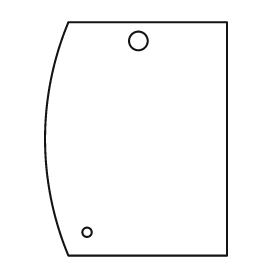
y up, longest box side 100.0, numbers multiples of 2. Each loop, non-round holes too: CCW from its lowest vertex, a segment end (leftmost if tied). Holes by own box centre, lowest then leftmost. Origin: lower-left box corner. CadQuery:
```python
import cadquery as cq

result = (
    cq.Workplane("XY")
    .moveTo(10.0, 0.0)
    .lineTo(78.0, 0.0)
    .lineTo(78.0, 100.0)
    .lineTo(10.0, 100.0)
    .threePointArc((0.0, 50.0), (10.0, 0.0))
    .close()
    .moveTo(18.0, 10.0)
    .circle(2.0)
    .moveTo(40.0, 92.0)
    .circle(4.0)
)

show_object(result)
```